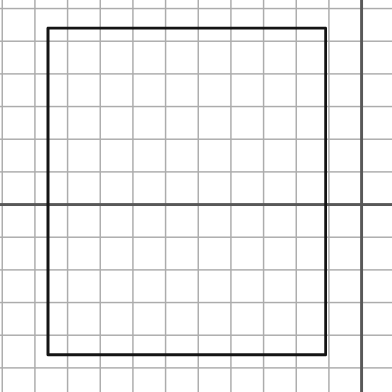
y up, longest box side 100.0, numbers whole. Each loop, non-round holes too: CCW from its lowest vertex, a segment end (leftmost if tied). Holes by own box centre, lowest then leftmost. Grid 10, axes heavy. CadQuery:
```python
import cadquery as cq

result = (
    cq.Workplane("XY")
    .moveTo(-96.0, -46.0)
    .lineTo(-11.0, -46.0)
    .lineTo(-11.0, 54.0)
    .lineTo(-96.0, 54.0)
    .close()
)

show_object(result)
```